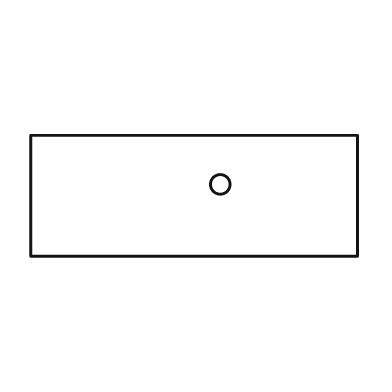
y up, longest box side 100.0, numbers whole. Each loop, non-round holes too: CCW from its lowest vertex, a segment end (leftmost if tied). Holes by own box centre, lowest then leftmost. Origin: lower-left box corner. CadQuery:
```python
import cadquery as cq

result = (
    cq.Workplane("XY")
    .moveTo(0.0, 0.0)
    .lineTo(100.0, 0.0)
    .lineTo(100.0, 37.0)
    .lineTo(0.0, 37.0)
    .close()
    .moveTo(58.0, 22.0)
    .circle(3.0)
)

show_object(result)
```